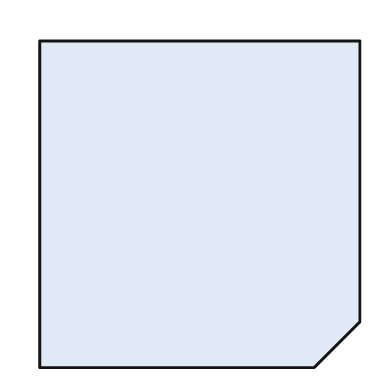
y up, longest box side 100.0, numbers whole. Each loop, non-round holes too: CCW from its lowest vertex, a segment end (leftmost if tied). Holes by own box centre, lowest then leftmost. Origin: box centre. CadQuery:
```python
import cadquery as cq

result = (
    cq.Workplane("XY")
    .moveTo(-49.0, -50.0)
    .lineTo(35.0, -50.0)
    .lineTo(49.0, -36.0)
    .lineTo(49.0, 50.0)
    .lineTo(-49.0, 50.0)
    .close()
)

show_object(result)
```